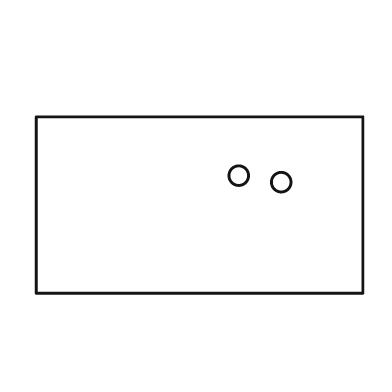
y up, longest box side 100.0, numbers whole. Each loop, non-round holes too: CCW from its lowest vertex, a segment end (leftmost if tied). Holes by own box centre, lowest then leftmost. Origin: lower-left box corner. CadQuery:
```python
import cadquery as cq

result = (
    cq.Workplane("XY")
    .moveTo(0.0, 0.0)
    .lineTo(100.0, 0.0)
    .lineTo(100.0, 54.0)
    .lineTo(0.0, 54.0)
    .close()
    .moveTo(75.0, 34.0)
    .circle(3.0)
    .moveTo(62.0, 36.0)
    .circle(3.0)
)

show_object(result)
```